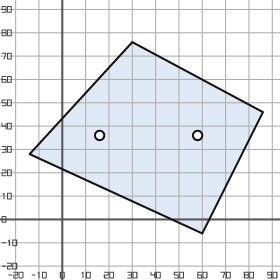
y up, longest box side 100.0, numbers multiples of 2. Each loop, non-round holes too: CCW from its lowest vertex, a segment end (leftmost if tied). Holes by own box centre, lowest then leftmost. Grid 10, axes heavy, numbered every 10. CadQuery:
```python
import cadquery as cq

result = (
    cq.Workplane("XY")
    .moveTo(60.0, -6.0)
    .lineTo(86.0, 46.0)
    .lineTo(30.0, 76.0)
    .lineTo(-14.0, 28.0)
    .close()
    .moveTo(16.0, 36.0)
    .circle(2.0)
    .moveTo(58.0, 36.0)
    .circle(2.0)
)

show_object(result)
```